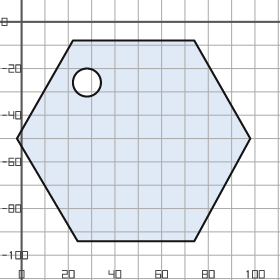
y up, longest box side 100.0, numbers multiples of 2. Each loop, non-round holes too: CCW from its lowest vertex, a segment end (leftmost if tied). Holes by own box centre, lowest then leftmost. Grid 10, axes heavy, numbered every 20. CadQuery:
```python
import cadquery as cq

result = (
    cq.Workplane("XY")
    .moveTo(24.0, -94.0)
    .lineTo(74.0, -94.0)
    .lineTo(98.0, -50.0)
    .lineTo(74.0, -8.0)
    .lineTo(22.0, -8.0)
    .lineTo(-2.0, -50.0)
    .close()
    .moveTo(28.0, -26.0)
    .circle(6.0)
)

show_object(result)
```